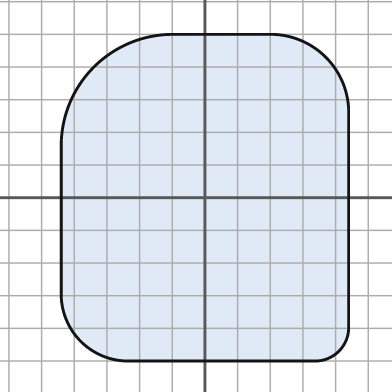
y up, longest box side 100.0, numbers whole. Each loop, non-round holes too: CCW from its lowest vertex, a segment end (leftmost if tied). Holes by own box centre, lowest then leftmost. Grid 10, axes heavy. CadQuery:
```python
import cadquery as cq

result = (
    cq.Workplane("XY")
    .moveTo(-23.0, -50.0)
    .lineTo(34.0, -50.0)
    .threePointArc((41.0, -47.0), (44.0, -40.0))
    .lineTo(44.0, 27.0)
    .threePointArc((37.0, 43.0), (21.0, 50.0))
    .lineTo(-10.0, 50.0)
    .threePointArc((-34.0, 40.0), (-44.0, 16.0))
    .lineTo(-44.0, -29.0)
    .threePointArc((-38.0, -44.0), (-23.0, -50.0))
    .close()
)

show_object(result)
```